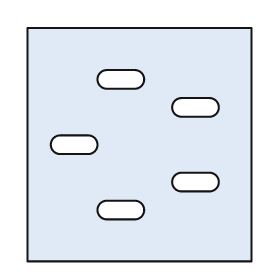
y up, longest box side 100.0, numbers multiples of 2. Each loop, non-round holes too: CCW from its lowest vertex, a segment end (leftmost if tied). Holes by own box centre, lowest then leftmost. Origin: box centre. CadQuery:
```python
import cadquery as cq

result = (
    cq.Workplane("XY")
    .moveTo(-48.0, -50.0)
    .lineTo(48.0, -50.0)
    .lineTo(48.0, 50.0)
    .lineTo(-48.0, 50.0)
    .close()
    .moveTo(-14.0, -32.0)
    .lineTo(-2.0, -32.0)
    .threePointArc((2.0, -28.0), (-2.0, -24.0))
    .lineTo(-14.0, -24.0)
    .threePointArc((-18.0, -28.0), (-14.0, -32.0))
    .close()
    .moveTo(18.0, -20.0)
    .lineTo(30.0, -20.0)
    .threePointArc((34.0, -16.0), (30.0, -12.0))
    .lineTo(18.0, -12.0)
    .threePointArc((14.0, -16.0), (18.0, -20.0))
    .close()
    .moveTo(-34.0, -4.0)
    .lineTo(-22.0, -4.0)
    .threePointArc((-18.0, 0.0), (-22.0, 4.0))
    .lineTo(-34.0, 4.0)
    .threePointArc((-38.0, 0.0), (-34.0, -4.0))
    .close()
    .moveTo(18.0, 12.0)
    .lineTo(30.0, 12.0)
    .threePointArc((34.0, 16.0), (30.0, 20.0))
    .lineTo(18.0, 20.0)
    .threePointArc((14.0, 16.0), (18.0, 12.0))
    .close()
    .moveTo(-14.0, 24.0)
    .lineTo(-2.0, 24.0)
    .threePointArc((2.0, 28.0), (-2.0, 32.0))
    .lineTo(-14.0, 32.0)
    .threePointArc((-18.0, 28.0), (-14.0, 24.0))
    .close()
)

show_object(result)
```